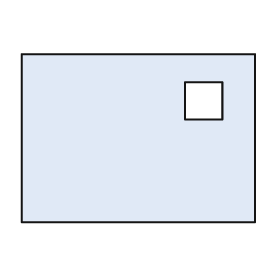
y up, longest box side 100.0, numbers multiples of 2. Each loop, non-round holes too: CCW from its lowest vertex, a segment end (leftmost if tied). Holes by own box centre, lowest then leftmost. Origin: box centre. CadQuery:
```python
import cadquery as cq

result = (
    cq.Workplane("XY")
    .moveTo(-50.0, -36.0)
    .lineTo(50.0, -36.0)
    .lineTo(50.0, 36.0)
    .lineTo(-50.0, 36.0)
    .close()
    .moveTo(20.0, 8.0)
    .lineTo(36.0, 8.0)
    .lineTo(36.0, 24.0)
    .lineTo(20.0, 24.0)
    .close()
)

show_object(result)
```